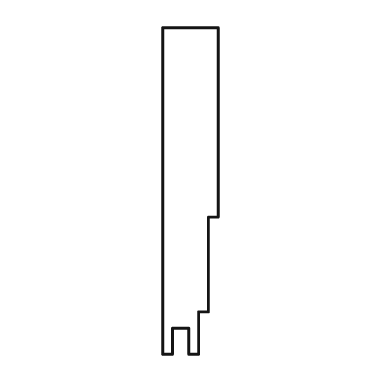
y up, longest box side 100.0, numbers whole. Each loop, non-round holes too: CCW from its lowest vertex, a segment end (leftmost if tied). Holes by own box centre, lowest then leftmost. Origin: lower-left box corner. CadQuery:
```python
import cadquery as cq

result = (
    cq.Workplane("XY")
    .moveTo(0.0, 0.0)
    .lineTo(3.0, 0.0)
    .lineTo(3.0, 8.0)
    .lineTo(8.0, 8.0)
    .lineTo(8.0, 0.0)
    .lineTo(11.0, 0.0)
    .lineTo(11.0, 13.0)
    .lineTo(14.0, 13.0)
    .lineTo(14.0, 42.0)
    .lineTo(17.0, 42.0)
    .lineTo(17.0, 100.0)
    .lineTo(0.0, 100.0)
    .close()
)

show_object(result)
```